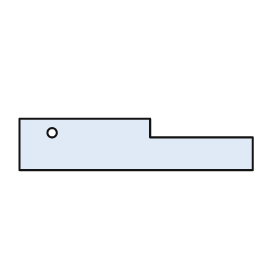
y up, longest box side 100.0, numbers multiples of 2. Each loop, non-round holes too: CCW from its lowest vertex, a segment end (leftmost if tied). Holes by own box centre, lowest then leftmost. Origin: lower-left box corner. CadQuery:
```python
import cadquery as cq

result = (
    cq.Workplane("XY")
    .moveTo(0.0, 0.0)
    .lineTo(100.0, 0.0)
    .lineTo(100.0, 14.0)
    .lineTo(56.0, 14.0)
    .lineTo(56.0, 22.0)
    .lineTo(0.0, 22.0)
    .close()
    .moveTo(14.0, 16.0)
    .circle(2.0)
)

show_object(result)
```